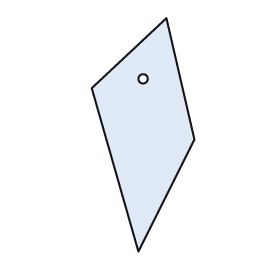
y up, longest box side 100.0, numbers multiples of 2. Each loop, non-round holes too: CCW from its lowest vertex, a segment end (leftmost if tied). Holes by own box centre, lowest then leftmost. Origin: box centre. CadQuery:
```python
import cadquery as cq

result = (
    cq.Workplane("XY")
    .moveTo(-2.0, -50.0)
    .lineTo(22.0, -2.0)
    .lineTo(10.0, 50.0)
    .lineTo(-22.0, 20.0)
    .close()
    .moveTo(0.0, 24.0)
    .circle(2.0)
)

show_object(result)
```